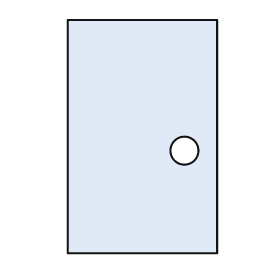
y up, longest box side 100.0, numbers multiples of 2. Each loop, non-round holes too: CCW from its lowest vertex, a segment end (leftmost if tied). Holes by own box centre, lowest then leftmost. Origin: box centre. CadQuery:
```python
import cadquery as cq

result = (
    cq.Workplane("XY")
    .moveTo(-32.0, -50.0)
    .lineTo(32.0, -50.0)
    .lineTo(32.0, 50.0)
    .lineTo(-32.0, 50.0)
    .close()
    .moveTo(18.0, -6.0)
    .circle(6.0)
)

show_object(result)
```